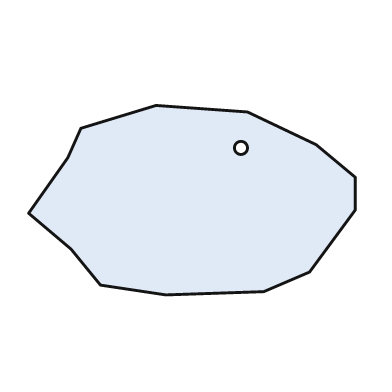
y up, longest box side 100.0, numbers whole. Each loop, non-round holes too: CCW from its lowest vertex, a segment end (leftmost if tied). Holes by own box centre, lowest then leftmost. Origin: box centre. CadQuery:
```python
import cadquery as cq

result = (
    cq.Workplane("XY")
    .moveTo(-8.0, -29.0)
    .lineTo(22.0, -28.0)
    .lineTo(36.0, -22.0)
    .lineTo(50.0, -3.0)
    .lineTo(50.0, 7.0)
    .lineTo(38.0, 17.0)
    .lineTo(17.0, 27.0)
    .lineTo(-11.0, 29.0)
    .lineTo(-34.0, 22.0)
    .lineTo(-38.0, 13.0)
    .lineTo(-50.0, -4.0)
    .lineTo(-37.0, -15.0)
    .lineTo(-28.0, -26.0)
    .close()
    .moveTo(15.0, 16.0)
    .circle(2.0)
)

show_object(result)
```